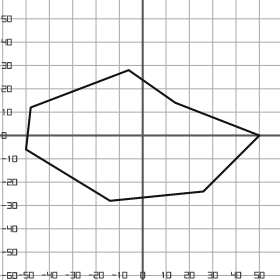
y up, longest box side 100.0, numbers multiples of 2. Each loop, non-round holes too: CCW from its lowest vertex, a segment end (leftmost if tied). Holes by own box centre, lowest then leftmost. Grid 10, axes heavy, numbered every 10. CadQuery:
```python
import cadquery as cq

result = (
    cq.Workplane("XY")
    .moveTo(-14.0, -28.0)
    .lineTo(26.0, -24.0)
    .lineTo(50.0, 0.0)
    .lineTo(14.0, 14.0)
    .lineTo(-6.0, 28.0)
    .lineTo(-48.0, 12.0)
    .lineTo(-50.0, -6.0)
    .close()
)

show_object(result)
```